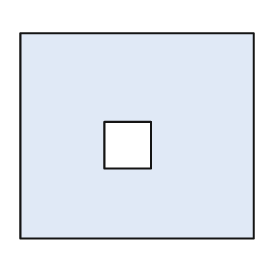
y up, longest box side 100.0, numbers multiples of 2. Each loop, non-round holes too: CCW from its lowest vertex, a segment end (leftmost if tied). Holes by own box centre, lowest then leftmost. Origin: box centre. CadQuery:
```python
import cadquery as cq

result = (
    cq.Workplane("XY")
    .moveTo(-50.0, -44.0)
    .lineTo(50.0, -44.0)
    .lineTo(50.0, 44.0)
    .lineTo(-50.0, 44.0)
    .close()
    .moveTo(-14.0, -14.0)
    .lineTo(6.0, -14.0)
    .lineTo(6.0, 6.0)
    .lineTo(-14.0, 6.0)
    .close()
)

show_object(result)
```